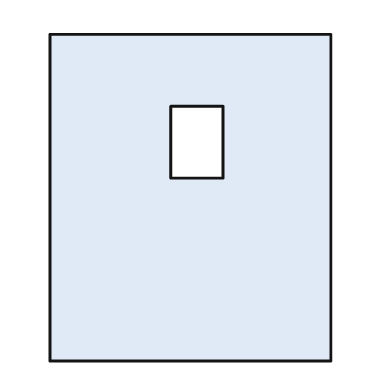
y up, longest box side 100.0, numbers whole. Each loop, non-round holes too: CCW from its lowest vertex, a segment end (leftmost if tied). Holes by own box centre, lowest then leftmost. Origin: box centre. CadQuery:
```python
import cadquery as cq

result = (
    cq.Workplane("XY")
    .moveTo(-43.0, -50.0)
    .lineTo(43.0, -50.0)
    .lineTo(43.0, 50.0)
    .lineTo(-43.0, 50.0)
    .close()
    .moveTo(-6.0, 6.0)
    .lineTo(10.0, 6.0)
    .lineTo(10.0, 28.0)
    .lineTo(-6.0, 28.0)
    .close()
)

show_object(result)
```